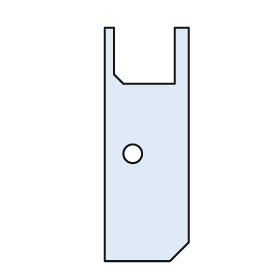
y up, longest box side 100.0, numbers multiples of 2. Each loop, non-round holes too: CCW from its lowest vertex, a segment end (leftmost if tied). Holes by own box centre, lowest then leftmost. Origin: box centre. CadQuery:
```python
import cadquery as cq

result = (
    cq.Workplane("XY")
    .moveTo(-18.0, -50.0)
    .lineTo(10.0, -50.0)
    .lineTo(18.0, -42.0)
    .lineTo(18.0, 50.0)
    .lineTo(12.0, 50.0)
    .lineTo(12.0, 26.0)
    .lineTo(-10.0, 26.0)
    .lineTo(-14.0, 30.0)
    .lineTo(-14.0, 50.0)
    .lineTo(-18.0, 50.0)
    .close()
    .moveTo(-6.0, -4.0)
    .circle(4.0)
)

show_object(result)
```